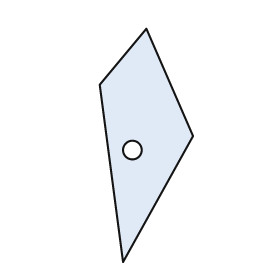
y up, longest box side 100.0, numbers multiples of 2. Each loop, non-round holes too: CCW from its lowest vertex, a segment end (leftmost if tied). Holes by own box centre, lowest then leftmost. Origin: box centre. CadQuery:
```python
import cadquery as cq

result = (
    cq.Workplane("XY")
    .moveTo(-10.0, -50.0)
    .lineTo(20.0, 4.0)
    .lineTo(0.0, 50.0)
    .lineTo(-20.0, 26.0)
    .close()
    .moveTo(-6.0, -2.0)
    .circle(4.0)
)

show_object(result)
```